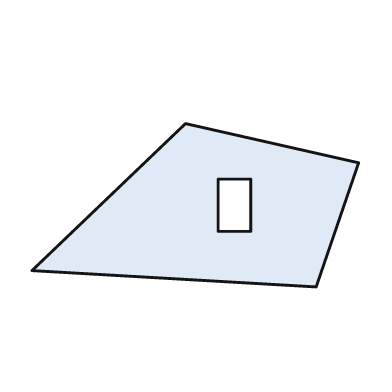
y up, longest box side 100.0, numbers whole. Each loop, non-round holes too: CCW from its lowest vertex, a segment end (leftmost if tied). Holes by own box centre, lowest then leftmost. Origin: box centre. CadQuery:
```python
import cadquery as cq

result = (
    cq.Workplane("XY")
    .moveTo(37.0, -25.0)
    .lineTo(50.0, 13.0)
    .lineTo(-3.0, 25.0)
    .lineTo(-50.0, -20.0)
    .close()
    .moveTo(7.0, -8.0)
    .lineTo(17.0, -8.0)
    .lineTo(17.0, 8.0)
    .lineTo(7.0, 8.0)
    .close()
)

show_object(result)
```